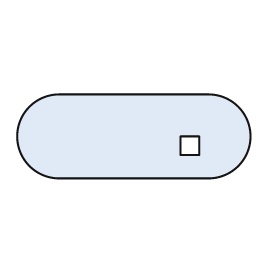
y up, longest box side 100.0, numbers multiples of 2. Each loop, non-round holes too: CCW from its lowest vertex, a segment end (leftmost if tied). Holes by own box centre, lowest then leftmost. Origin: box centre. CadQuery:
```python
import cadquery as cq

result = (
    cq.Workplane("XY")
    .moveTo(-32.0, -18.0)
    .lineTo(32.0, -18.0)
    .threePointArc((50.0, 0.0), (32.0, 18.0))
    .lineTo(-32.0, 18.0)
    .threePointArc((-50.0, 0.0), (-32.0, -18.0))
    .close()
    .moveTo(20.0, -8.0)
    .lineTo(28.0, -8.0)
    .lineTo(28.0, 0.0)
    .lineTo(20.0, 0.0)
    .close()
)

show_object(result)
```